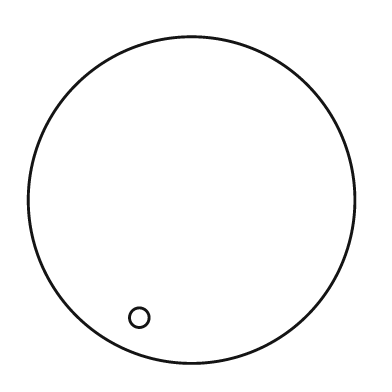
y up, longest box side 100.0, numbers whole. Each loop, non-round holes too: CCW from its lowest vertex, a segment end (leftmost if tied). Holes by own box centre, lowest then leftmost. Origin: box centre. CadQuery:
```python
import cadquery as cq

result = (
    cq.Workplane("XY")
    .moveTo(0.0, 0.0)
    .circle(50.0)
    .moveTo(-16.0, -36.0)
    .circle(3.0)
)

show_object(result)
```